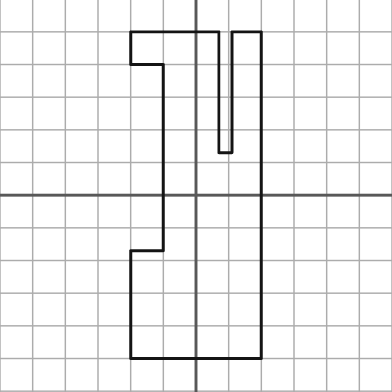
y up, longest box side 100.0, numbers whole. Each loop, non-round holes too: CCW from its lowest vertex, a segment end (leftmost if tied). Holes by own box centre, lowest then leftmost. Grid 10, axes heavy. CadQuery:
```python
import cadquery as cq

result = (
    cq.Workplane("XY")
    .moveTo(-20.0, -50.0)
    .lineTo(20.0, -50.0)
    .lineTo(20.0, 50.0)
    .lineTo(11.0, 50.0)
    .lineTo(11.0, 13.0)
    .lineTo(7.0, 13.0)
    .lineTo(7.0, 50.0)
    .lineTo(-20.0, 50.0)
    .lineTo(-20.0, 40.0)
    .lineTo(-10.0, 40.0)
    .lineTo(-10.0, -17.0)
    .lineTo(-20.0, -17.0)
    .close()
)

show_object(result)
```